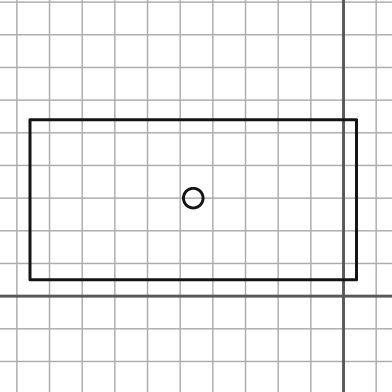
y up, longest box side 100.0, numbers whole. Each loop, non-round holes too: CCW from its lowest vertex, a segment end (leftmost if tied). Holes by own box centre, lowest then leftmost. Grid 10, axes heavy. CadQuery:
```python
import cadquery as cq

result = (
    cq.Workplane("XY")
    .moveTo(-96.0, 5.0)
    .lineTo(4.0, 5.0)
    .lineTo(4.0, 54.0)
    .lineTo(-96.0, 54.0)
    .close()
    .moveTo(-46.0, 30.0)
    .circle(3.0)
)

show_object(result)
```